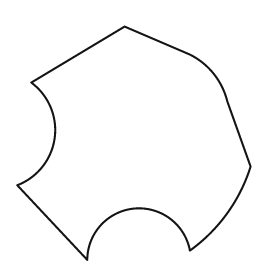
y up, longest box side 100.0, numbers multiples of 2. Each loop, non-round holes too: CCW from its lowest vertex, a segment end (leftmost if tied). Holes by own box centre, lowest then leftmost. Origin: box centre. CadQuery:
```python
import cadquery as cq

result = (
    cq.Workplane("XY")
    .moveTo(-20.0, -50.0)
    .threePointArc((0.0, -28.0), (24.0, -46.0))
    .threePointArc((40.0, -30.0), (50.0, -10.0))
    .lineTo(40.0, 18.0)
    .threePointArc((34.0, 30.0), (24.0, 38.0))
    .lineTo(-4.0, 50.0)
    .lineTo(-44.0, 26.0)
    .threePointArc((-34.0, 2.0), (-50.0, -18.0))
    .close()
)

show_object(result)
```